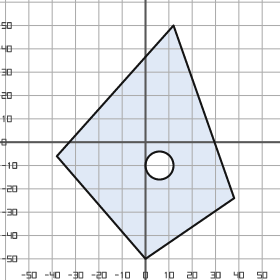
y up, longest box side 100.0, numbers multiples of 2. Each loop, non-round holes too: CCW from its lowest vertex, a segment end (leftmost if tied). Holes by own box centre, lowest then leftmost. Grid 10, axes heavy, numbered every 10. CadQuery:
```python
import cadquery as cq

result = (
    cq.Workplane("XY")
    .moveTo(0.0, -50.0)
    .lineTo(38.0, -24.0)
    .lineTo(12.0, 50.0)
    .lineTo(-38.0, -6.0)
    .close()
    .moveTo(6.0, -10.0)
    .circle(6.0)
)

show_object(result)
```